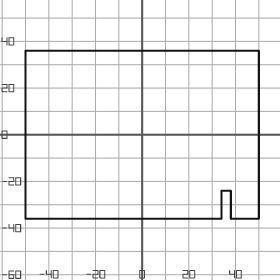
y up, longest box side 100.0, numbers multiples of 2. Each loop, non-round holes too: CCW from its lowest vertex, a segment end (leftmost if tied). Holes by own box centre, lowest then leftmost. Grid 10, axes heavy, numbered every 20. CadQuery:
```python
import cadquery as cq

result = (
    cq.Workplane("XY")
    .moveTo(-50.0, -36.0)
    .lineTo(34.0, -36.0)
    .lineTo(34.0, -24.0)
    .lineTo(38.0, -24.0)
    .lineTo(38.0, -36.0)
    .lineTo(50.0, -36.0)
    .lineTo(50.0, 36.0)
    .lineTo(-50.0, 36.0)
    .close()
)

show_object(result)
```